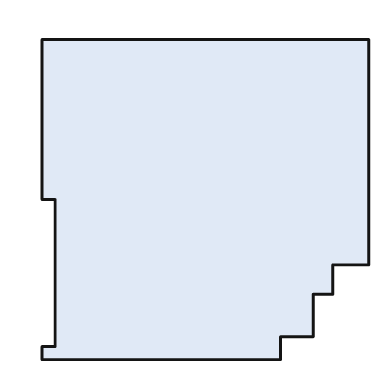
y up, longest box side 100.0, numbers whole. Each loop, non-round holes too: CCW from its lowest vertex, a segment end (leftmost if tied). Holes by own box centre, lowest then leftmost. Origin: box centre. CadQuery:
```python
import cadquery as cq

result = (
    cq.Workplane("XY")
    .moveTo(-50.0, -49.0)
    .lineTo(23.0, -49.0)
    .lineTo(23.0, -42.0)
    .lineTo(33.0, -42.0)
    .lineTo(33.0, -29.0)
    .lineTo(39.0, -29.0)
    .lineTo(39.0, -20.0)
    .lineTo(50.0, -20.0)
    .lineTo(50.0, 49.0)
    .lineTo(-50.0, 49.0)
    .lineTo(-50.0, 0.0)
    .lineTo(-46.0, 0.0)
    .lineTo(-46.0, -45.0)
    .lineTo(-50.0, -45.0)
    .close()
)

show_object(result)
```